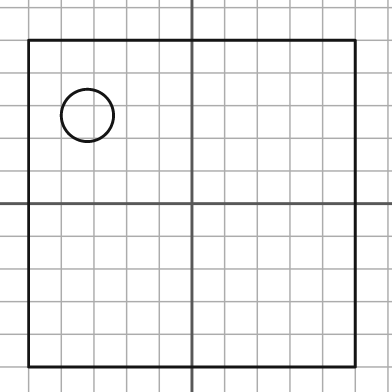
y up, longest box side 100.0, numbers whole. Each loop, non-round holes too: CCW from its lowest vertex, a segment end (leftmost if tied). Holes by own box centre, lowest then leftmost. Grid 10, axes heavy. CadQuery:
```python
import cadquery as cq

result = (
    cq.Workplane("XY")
    .moveTo(-50.0, -50.0)
    .lineTo(50.0, -50.0)
    .lineTo(50.0, 50.0)
    .lineTo(-50.0, 50.0)
    .close()
    .moveTo(-32.0, 27.0)
    .circle(8.0)
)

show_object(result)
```